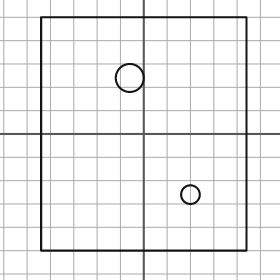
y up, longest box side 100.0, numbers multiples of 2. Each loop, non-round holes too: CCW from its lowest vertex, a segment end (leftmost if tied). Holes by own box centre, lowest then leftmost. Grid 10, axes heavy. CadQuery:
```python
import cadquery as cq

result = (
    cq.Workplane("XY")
    .moveTo(-44.0, -50.0)
    .lineTo(44.0, -50.0)
    .lineTo(44.0, 50.0)
    .lineTo(-44.0, 50.0)
    .close()
    .moveTo(20.0, -26.0)
    .circle(4.0)
    .moveTo(-6.0, 24.0)
    .circle(6.0)
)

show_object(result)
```